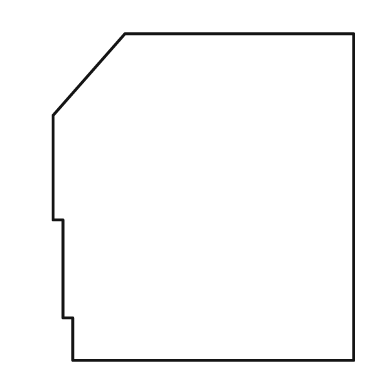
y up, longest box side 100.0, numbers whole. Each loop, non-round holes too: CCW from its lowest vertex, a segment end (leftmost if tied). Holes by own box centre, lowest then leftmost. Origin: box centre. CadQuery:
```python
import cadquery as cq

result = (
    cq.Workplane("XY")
    .moveTo(-40.0, -50.0)
    .lineTo(46.0, -50.0)
    .lineTo(46.0, 50.0)
    .lineTo(-24.0, 50.0)
    .lineTo(-46.0, 25.0)
    .lineTo(-46.0, -7.0)
    .lineTo(-43.0, -7.0)
    .lineTo(-43.0, -37.0)
    .lineTo(-40.0, -37.0)
    .close()
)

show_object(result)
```